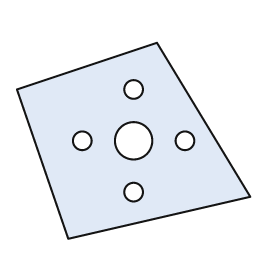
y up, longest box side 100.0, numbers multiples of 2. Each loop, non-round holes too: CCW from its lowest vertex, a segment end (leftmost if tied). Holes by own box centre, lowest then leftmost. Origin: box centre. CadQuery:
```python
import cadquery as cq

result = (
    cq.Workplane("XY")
    .moveTo(-28.0, -42.0)
    .lineTo(50.0, -24.0)
    .lineTo(10.0, 42.0)
    .lineTo(-50.0, 22.0)
    .close()
    .moveTo(0.0, -22.0)
    .circle(4.0)
    .moveTo(-22.0, 0.0)
    .circle(4.0)
    .moveTo(0.0, 0.0)
    .circle(8.0)
    .moveTo(22.0, 0.0)
    .circle(4.0)
    .moveTo(0.0, 22.0)
    .circle(4.0)
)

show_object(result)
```